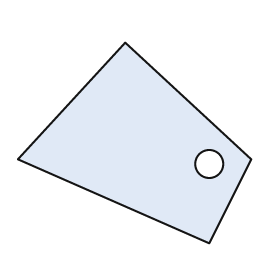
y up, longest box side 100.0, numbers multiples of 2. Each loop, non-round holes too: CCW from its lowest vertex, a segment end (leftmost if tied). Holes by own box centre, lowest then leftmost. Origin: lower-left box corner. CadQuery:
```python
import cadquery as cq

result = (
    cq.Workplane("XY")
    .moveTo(82.0, 0.0)
    .lineTo(100.0, 36.0)
    .lineTo(46.0, 86.0)
    .lineTo(0.0, 36.0)
    .close()
    .moveTo(82.0, 34.0)
    .circle(6.0)
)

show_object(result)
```